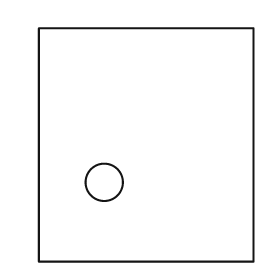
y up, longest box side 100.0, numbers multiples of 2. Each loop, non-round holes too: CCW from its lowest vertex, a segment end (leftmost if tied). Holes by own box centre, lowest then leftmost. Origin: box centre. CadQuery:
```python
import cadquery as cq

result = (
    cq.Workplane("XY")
    .moveTo(-46.0, -50.0)
    .lineTo(46.0, -50.0)
    .lineTo(46.0, 50.0)
    .lineTo(-46.0, 50.0)
    .close()
    .moveTo(-18.0, -16.0)
    .circle(8.0)
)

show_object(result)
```